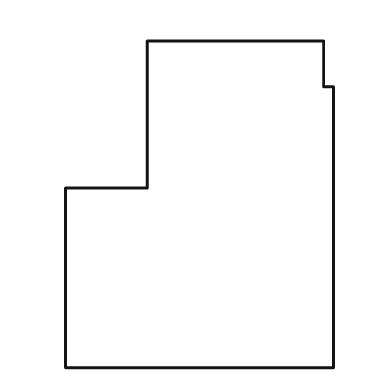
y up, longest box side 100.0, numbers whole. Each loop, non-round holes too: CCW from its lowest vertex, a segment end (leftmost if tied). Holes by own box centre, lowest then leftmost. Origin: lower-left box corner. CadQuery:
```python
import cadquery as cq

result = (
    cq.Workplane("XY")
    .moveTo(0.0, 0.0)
    .lineTo(82.0, 0.0)
    .lineTo(82.0, 86.0)
    .lineTo(79.0, 86.0)
    .lineTo(79.0, 100.0)
    .lineTo(25.0, 100.0)
    .lineTo(25.0, 55.0)
    .lineTo(0.0, 55.0)
    .close()
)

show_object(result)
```